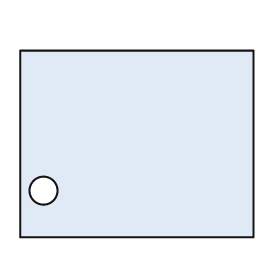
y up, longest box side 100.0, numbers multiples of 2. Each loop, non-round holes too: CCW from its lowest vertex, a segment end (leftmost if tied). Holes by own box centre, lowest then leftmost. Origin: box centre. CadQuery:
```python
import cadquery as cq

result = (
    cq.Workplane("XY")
    .moveTo(-50.0, -40.0)
    .lineTo(50.0, -40.0)
    .lineTo(50.0, 40.0)
    .lineTo(-50.0, 40.0)
    .close()
    .moveTo(-40.0, -20.0)
    .circle(6.0)
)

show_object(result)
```